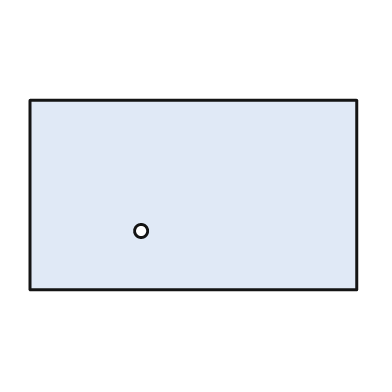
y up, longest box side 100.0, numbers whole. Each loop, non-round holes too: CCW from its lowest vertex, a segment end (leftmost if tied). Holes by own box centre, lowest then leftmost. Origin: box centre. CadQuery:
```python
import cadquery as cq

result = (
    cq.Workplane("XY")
    .moveTo(-50.0, -29.0)
    .lineTo(50.0, -29.0)
    .lineTo(50.0, 29.0)
    .lineTo(-50.0, 29.0)
    .close()
    .moveTo(-16.0, -11.0)
    .circle(2.0)
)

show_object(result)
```